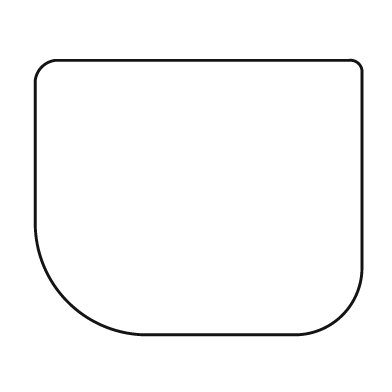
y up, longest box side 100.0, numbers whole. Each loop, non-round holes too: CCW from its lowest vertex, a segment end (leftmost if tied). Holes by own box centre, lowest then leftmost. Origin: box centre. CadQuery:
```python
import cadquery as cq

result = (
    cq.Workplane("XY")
    .moveTo(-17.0, -42.0)
    .lineTo(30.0, -42.0)
    .threePointArc((44.0, -36.0), (50.0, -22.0))
    .lineTo(50.0, 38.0)
    .threePointArc((49.0, 41.0), (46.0, 42.0))
    .lineTo(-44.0, 42.0)
    .threePointArc((-48.0, 40.0), (-50.0, 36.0))
    .lineTo(-50.0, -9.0)
    .threePointArc((-40.0, -32.0), (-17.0, -42.0))
    .close()
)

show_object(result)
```